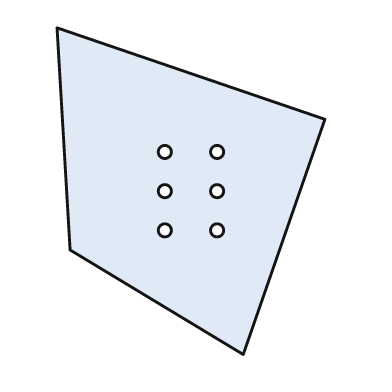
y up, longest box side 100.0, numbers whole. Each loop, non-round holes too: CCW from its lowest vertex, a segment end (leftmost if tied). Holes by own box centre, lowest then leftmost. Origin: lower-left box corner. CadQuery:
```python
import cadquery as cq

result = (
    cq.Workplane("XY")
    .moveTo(57.0, 0.0)
    .lineTo(82.0, 72.0)
    .lineTo(0.0, 100.0)
    .lineTo(4.0, 32.0)
    .close()
    .moveTo(33.0, 38.0)
    .circle(2.0)
    .moveTo(49.0, 38.0)
    .circle(2.0)
    .moveTo(33.0, 50.0)
    .circle(2.0)
    .moveTo(49.0, 50.0)
    .circle(2.0)
    .moveTo(33.0, 62.0)
    .circle(2.0)
    .moveTo(49.0, 62.0)
    .circle(2.0)
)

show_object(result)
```